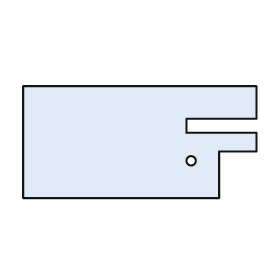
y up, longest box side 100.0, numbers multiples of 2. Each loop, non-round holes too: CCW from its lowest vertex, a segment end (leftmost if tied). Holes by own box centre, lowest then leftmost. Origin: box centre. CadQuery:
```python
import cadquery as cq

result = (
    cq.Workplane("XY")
    .moveTo(-50.0, -24.0)
    .lineTo(34.0, -24.0)
    .lineTo(34.0, -4.0)
    .lineTo(50.0, -4.0)
    .lineTo(50.0, 4.0)
    .lineTo(20.0, 4.0)
    .lineTo(20.0, 10.0)
    .lineTo(50.0, 10.0)
    .lineTo(50.0, 24.0)
    .lineTo(-50.0, 24.0)
    .close()
    .moveTo(22.0, -8.0)
    .circle(2.0)
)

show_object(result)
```